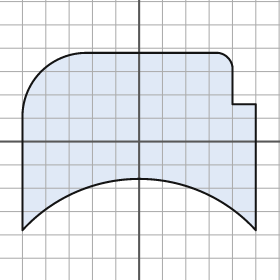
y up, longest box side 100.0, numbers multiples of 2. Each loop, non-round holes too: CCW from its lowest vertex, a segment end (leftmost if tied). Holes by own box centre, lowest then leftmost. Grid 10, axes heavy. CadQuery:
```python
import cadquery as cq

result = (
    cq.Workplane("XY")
    .moveTo(-50.0, -38.0)
    .threePointArc((0.0, -16.0), (50.0, -38.0))
    .lineTo(50.0, 16.0)
    .lineTo(40.0, 16.0)
    .lineTo(40.0, 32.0)
    .threePointArc((38.0, 36.0), (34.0, 38.0))
    .lineTo(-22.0, 38.0)
    .threePointArc((-42.0, 30.0), (-50.0, 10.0))
    .close()
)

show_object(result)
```